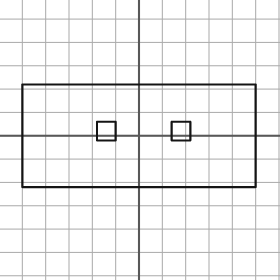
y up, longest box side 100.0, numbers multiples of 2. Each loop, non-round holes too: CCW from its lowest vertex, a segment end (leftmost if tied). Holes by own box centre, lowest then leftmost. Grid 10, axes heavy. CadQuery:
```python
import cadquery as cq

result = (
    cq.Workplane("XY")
    .moveTo(-50.0, -22.0)
    .lineTo(50.0, -22.0)
    .lineTo(50.0, 22.0)
    .lineTo(-50.0, 22.0)
    .close()
    .moveTo(-18.0, -2.0)
    .lineTo(-10.0, -2.0)
    .lineTo(-10.0, 6.0)
    .lineTo(-18.0, 6.0)
    .close()
    .moveTo(14.0, -2.0)
    .lineTo(22.0, -2.0)
    .lineTo(22.0, 6.0)
    .lineTo(14.0, 6.0)
    .close()
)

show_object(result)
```